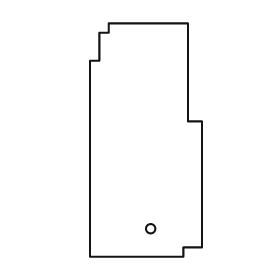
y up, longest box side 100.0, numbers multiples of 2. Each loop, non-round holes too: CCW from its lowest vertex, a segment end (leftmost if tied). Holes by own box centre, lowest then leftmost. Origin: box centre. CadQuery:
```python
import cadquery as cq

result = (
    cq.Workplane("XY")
    .moveTo(-24.0, -50.0)
    .lineTo(16.0, -50.0)
    .lineTo(16.0, -46.0)
    .lineTo(24.0, -46.0)
    .lineTo(24.0, 8.0)
    .lineTo(18.0, 8.0)
    .lineTo(18.0, 50.0)
    .lineTo(-16.0, 50.0)
    .lineTo(-16.0, 46.0)
    .lineTo(-20.0, 46.0)
    .lineTo(-20.0, 34.0)
    .lineTo(-24.0, 34.0)
    .close()
    .moveTo(2.0, -38.0)
    .circle(2.0)
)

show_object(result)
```